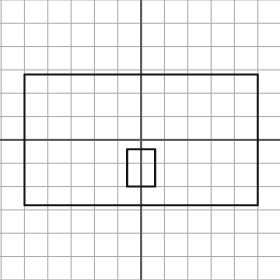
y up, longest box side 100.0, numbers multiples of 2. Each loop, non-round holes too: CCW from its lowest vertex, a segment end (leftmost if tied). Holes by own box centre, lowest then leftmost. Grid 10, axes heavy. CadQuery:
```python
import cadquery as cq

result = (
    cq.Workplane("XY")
    .moveTo(-50.0, -28.0)
    .lineTo(50.0, -28.0)
    .lineTo(50.0, 28.0)
    .lineTo(-50.0, 28.0)
    .close()
    .moveTo(-6.0, -20.0)
    .lineTo(6.0, -20.0)
    .lineTo(6.0, -4.0)
    .lineTo(-6.0, -4.0)
    .close()
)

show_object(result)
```